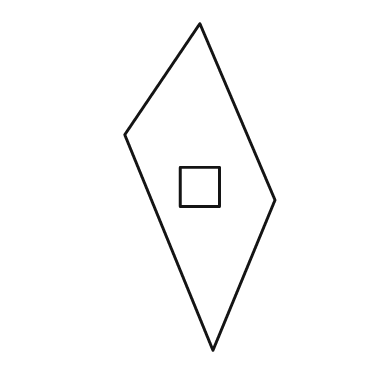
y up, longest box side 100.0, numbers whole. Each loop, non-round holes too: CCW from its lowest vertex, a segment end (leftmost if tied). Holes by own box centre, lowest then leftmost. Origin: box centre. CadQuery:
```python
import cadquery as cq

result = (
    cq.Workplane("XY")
    .moveTo(4.0, -50.0)
    .lineTo(23.0, -4.0)
    .lineTo(0.0, 50.0)
    .lineTo(-23.0, 16.0)
    .close()
    .moveTo(-6.0, -6.0)
    .lineTo(6.0, -6.0)
    .lineTo(6.0, 6.0)
    .lineTo(-6.0, 6.0)
    .close()
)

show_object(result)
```